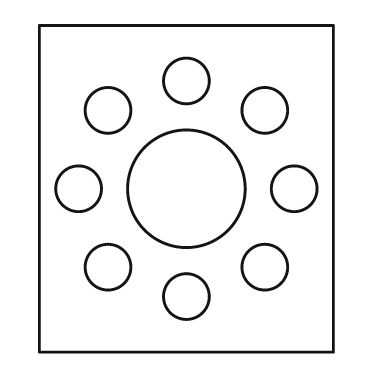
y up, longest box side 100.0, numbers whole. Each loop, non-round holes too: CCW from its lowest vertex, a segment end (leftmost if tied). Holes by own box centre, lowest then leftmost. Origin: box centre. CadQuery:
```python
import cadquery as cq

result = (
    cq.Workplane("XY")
    .moveTo(-45.0, -50.0)
    .lineTo(45.0, -50.0)
    .lineTo(45.0, 50.0)
    .lineTo(-45.0, 50.0)
    .close()
    .moveTo(0.0, -33.0)
    .circle(7.0)
    .moveTo(-24.0, -24.0)
    .circle(7.0)
    .moveTo(24.0, -24.0)
    .circle(7.0)
    .moveTo(-33.0, 0.0)
    .circle(7.0)
    .moveTo(0.0, 0.0)
    .circle(18.0)
    .moveTo(33.0, 0.0)
    .circle(7.0)
    .moveTo(-24.0, 24.0)
    .circle(7.0)
    .moveTo(24.0, 24.0)
    .circle(7.0)
    .moveTo(0.0, 33.0)
    .circle(7.0)
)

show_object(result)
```